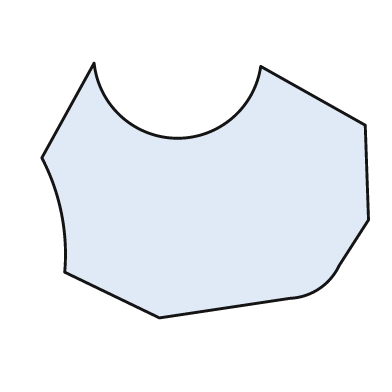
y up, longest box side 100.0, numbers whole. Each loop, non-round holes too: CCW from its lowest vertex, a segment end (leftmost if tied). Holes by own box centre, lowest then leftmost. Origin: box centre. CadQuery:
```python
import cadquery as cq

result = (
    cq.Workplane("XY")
    .moveTo(-14.0, -39.0)
    .lineTo(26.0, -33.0)
    .threePointArc((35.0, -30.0), (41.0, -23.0))
    .lineTo(50.0, -9.0)
    .lineTo(49.0, 20.0)
    .lineTo(17.0, 38.0)
    .threePointArc((-9.0, 16.0), (-34.0, 39.0))
    .lineTo(-50.0, 10.0)
    .threePointArc((-44.0, -7.0), (-43.0, -25.0))
    .close()
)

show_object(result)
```